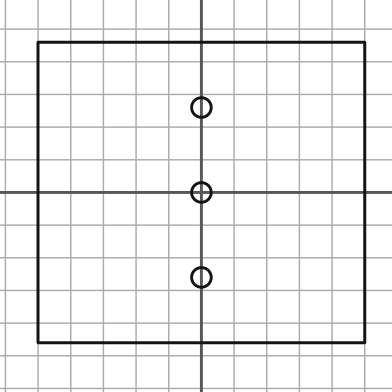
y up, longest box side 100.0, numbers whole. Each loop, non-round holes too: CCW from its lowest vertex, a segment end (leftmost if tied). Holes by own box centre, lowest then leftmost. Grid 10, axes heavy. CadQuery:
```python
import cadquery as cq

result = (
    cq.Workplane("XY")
    .moveTo(-50.0, -46.0)
    .lineTo(50.0, -46.0)
    .lineTo(50.0, 46.0)
    .lineTo(-50.0, 46.0)
    .close()
    .moveTo(0.0, -26.0)
    .circle(3.0)
    .moveTo(0.0, 0.0)
    .circle(3.0)
    .moveTo(0.0, 26.0)
    .circle(3.0)
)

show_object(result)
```